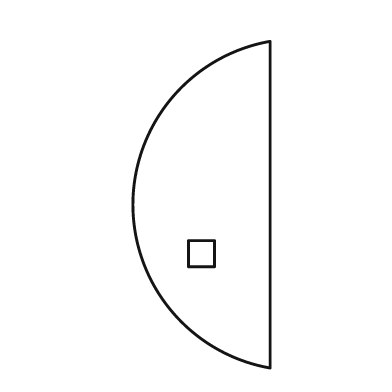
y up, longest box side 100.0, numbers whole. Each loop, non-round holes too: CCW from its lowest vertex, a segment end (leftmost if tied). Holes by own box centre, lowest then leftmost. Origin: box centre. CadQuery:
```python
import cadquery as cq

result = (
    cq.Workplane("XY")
    .moveTo(21.0, -50.0)
    .lineTo(21.0, 50.0)
    .threePointArc((-21.0, 0.0), (21.0, -50.0))
    .close()
    .moveTo(-4.0, -19.0)
    .lineTo(4.0, -19.0)
    .lineTo(4.0, -11.0)
    .lineTo(-4.0, -11.0)
    .close()
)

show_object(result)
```